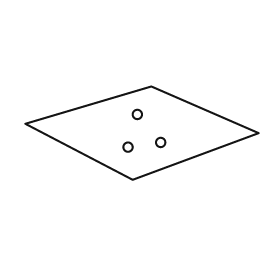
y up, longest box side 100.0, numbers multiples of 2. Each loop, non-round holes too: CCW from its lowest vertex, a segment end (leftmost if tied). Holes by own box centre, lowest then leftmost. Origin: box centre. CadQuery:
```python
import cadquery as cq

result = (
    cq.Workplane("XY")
    .moveTo(-4.0, -20.0)
    .lineTo(50.0, 0.0)
    .lineTo(4.0, 20.0)
    .lineTo(-50.0, 4.0)
    .close()
    .moveTo(-6.0, -6.0)
    .circle(2.0)
    .moveTo(8.0, -4.0)
    .circle(2.0)
    .moveTo(-2.0, 8.0)
    .circle(2.0)
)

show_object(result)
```